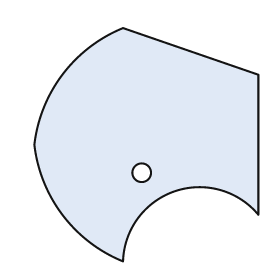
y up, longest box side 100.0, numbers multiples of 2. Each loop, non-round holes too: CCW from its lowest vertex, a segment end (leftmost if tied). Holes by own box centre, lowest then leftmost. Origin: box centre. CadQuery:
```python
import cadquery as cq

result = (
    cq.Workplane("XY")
    .moveTo(-10.0, -50.0)
    .threePointArc((12.0, -20.0), (48.0, -30.0))
    .lineTo(48.0, 30.0)
    .lineTo(-10.0, 50.0)
    .threePointArc((-36.0, 30.0), (-48.0, 0.0))
    .threePointArc((-36.0, -30.0), (-10.0, -50.0))
    .close()
    .moveTo(-2.0, -12.0)
    .circle(4.0)
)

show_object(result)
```